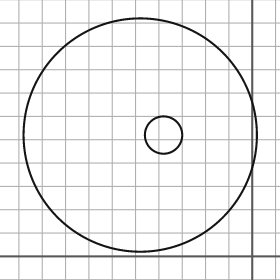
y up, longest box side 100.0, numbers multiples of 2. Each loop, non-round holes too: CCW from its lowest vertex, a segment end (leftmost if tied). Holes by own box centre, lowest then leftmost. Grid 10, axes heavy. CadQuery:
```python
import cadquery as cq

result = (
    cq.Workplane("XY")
    .moveTo(-48.0, 52.0)
    .circle(50.0)
    .moveTo(-38.0, 52.0)
    .circle(8.0)
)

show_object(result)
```